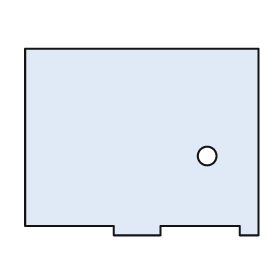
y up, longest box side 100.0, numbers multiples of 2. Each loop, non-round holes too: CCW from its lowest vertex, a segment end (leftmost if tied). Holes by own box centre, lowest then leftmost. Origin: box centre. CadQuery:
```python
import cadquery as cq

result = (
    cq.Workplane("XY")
    .moveTo(-12.0, -40.0)
    .lineTo(8.0, -40.0)
    .lineTo(8.0, -36.0)
    .lineTo(42.0, -36.0)
    .lineTo(42.0, -40.0)
    .lineTo(50.0, -40.0)
    .lineTo(50.0, 40.0)
    .lineTo(-50.0, 40.0)
    .lineTo(-50.0, -36.0)
    .lineTo(-12.0, -36.0)
    .close()
    .moveTo(28.0, -6.0)
    .circle(4.0)
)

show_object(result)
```